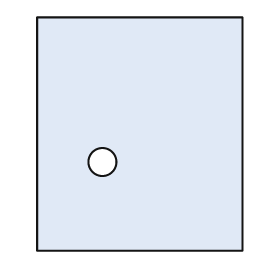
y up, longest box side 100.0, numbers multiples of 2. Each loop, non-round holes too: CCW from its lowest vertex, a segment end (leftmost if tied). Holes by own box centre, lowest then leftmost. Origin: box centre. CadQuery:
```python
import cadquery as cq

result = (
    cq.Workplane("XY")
    .moveTo(-44.0, -50.0)
    .lineTo(44.0, -50.0)
    .lineTo(44.0, 50.0)
    .lineTo(-44.0, 50.0)
    .close()
    .moveTo(-16.0, -12.0)
    .circle(6.0)
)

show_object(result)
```